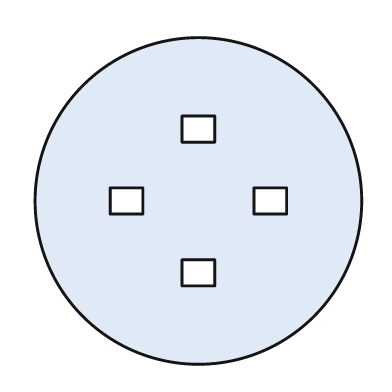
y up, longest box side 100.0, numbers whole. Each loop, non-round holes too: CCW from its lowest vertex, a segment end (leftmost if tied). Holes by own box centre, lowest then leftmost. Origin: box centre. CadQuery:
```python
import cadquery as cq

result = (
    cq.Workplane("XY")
    .moveTo(0.0, 0.0)
    .circle(50.0)
    .moveTo(-5.0, -26.0)
    .lineTo(5.0, -26.0)
    .lineTo(5.0, -18.0)
    .lineTo(-5.0, -18.0)
    .close()
    .moveTo(-27.0, -4.0)
    .lineTo(-17.0, -4.0)
    .lineTo(-17.0, 4.0)
    .lineTo(-27.0, 4.0)
    .close()
    .moveTo(17.0, -4.0)
    .lineTo(27.0, -4.0)
    .lineTo(27.0, 4.0)
    .lineTo(17.0, 4.0)
    .close()
    .moveTo(-5.0, 18.0)
    .lineTo(5.0, 18.0)
    .lineTo(5.0, 26.0)
    .lineTo(-5.0, 26.0)
    .close()
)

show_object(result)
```